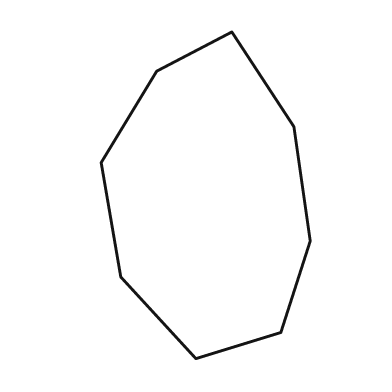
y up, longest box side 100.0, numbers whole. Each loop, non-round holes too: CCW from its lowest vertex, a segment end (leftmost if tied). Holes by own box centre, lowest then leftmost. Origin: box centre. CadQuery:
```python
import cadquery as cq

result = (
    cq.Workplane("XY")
    .moveTo(-3.0, -50.0)
    .lineTo(23.0, -42.0)
    .lineTo(32.0, -14.0)
    .lineTo(27.0, 21.0)
    .lineTo(8.0, 50.0)
    .lineTo(-15.0, 38.0)
    .lineTo(-32.0, 10.0)
    .lineTo(-26.0, -25.0)
    .close()
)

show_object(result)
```